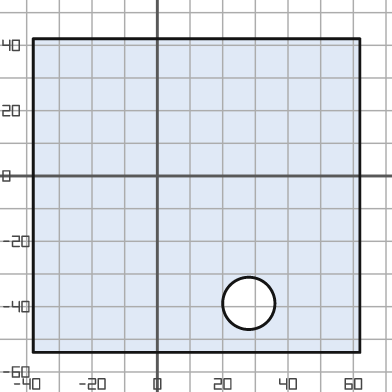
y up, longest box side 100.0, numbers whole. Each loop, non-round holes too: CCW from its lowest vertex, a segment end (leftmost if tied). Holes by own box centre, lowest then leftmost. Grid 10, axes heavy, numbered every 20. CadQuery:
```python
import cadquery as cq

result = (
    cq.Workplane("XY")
    .moveTo(-38.0, -54.0)
    .lineTo(62.0, -54.0)
    .lineTo(62.0, 42.0)
    .lineTo(-38.0, 42.0)
    .close()
    .moveTo(28.0, -39.0)
    .circle(8.0)
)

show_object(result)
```